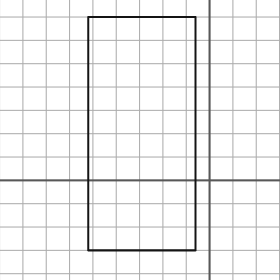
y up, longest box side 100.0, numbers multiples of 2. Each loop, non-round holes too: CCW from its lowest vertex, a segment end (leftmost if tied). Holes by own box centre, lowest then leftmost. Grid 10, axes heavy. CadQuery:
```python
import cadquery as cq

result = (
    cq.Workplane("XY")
    .moveTo(-52.0, -30.0)
    .lineTo(-6.0, -30.0)
    .lineTo(-6.0, 70.0)
    .lineTo(-52.0, 70.0)
    .close()
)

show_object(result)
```